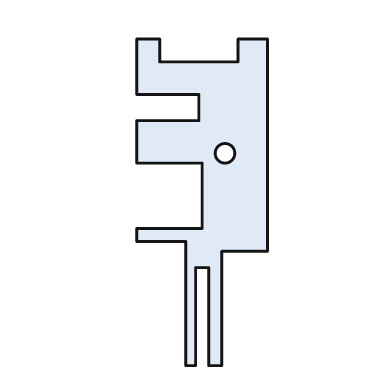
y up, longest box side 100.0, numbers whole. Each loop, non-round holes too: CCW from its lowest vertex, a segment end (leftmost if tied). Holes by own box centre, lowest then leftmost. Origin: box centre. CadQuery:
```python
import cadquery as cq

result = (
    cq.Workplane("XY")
    .moveTo(-5.0, -50.0)
    .lineTo(-2.0, -50.0)
    .lineTo(-2.0, -20.0)
    .lineTo(2.0, -20.0)
    .lineTo(2.0, -50.0)
    .lineTo(6.0, -50.0)
    .lineTo(6.0, -15.0)
    .lineTo(20.0, -15.0)
    .lineTo(20.0, 50.0)
    .lineTo(11.0, 50.0)
    .lineTo(11.0, 43.0)
    .lineTo(-13.0, 43.0)
    .lineTo(-13.0, 50.0)
    .lineTo(-20.0, 50.0)
    .lineTo(-20.0, 33.0)
    .lineTo(-1.0, 33.0)
    .lineTo(-1.0, 25.0)
    .lineTo(-20.0, 25.0)
    .lineTo(-20.0, 12.0)
    .lineTo(0.0, 12.0)
    .lineTo(0.0, -8.0)
    .lineTo(-20.0, -8.0)
    .lineTo(-20.0, -12.0)
    .lineTo(-5.0, -12.0)
    .close()
    .moveTo(7.0, 15.0)
    .circle(3.0)
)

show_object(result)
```